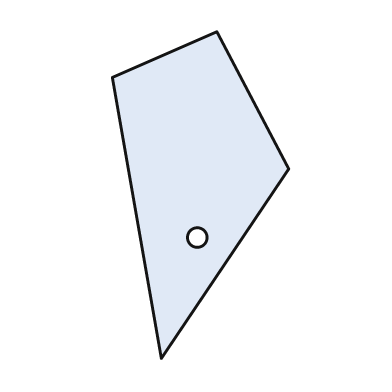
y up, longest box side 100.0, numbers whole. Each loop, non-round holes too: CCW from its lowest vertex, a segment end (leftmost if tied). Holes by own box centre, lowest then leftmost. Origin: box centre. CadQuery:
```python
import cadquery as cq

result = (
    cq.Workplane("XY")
    .moveTo(-12.0, -50.0)
    .lineTo(27.0, 8.0)
    .lineTo(5.0, 50.0)
    .lineTo(-27.0, 36.0)
    .close()
    .moveTo(-1.0, -13.0)
    .circle(3.0)
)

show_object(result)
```